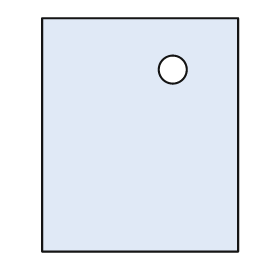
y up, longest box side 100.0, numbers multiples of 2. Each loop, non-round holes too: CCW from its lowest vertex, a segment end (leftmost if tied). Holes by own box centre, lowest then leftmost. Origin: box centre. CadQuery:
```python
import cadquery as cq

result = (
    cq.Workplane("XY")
    .moveTo(-42.0, -50.0)
    .lineTo(42.0, -50.0)
    .lineTo(42.0, 50.0)
    .lineTo(-42.0, 50.0)
    .close()
    .moveTo(14.0, 28.0)
    .circle(6.0)
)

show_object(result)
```